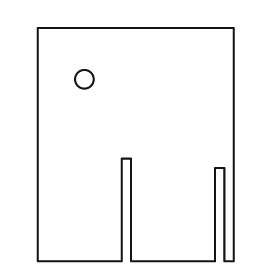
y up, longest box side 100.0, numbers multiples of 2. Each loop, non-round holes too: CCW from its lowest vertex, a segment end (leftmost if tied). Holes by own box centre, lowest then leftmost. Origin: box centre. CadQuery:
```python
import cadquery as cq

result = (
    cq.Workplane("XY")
    .moveTo(-42.0, -50.0)
    .lineTo(-6.0, -50.0)
    .lineTo(-6.0, -6.0)
    .lineTo(-2.0, -6.0)
    .lineTo(-2.0, -50.0)
    .lineTo(34.0, -50.0)
    .lineTo(34.0, -10.0)
    .lineTo(38.0, -10.0)
    .lineTo(38.0, -50.0)
    .lineTo(42.0, -50.0)
    .lineTo(42.0, 50.0)
    .lineTo(-42.0, 50.0)
    .close()
    .moveTo(-22.0, 28.0)
    .circle(4.0)
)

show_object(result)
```